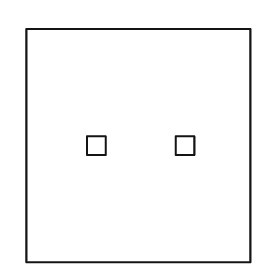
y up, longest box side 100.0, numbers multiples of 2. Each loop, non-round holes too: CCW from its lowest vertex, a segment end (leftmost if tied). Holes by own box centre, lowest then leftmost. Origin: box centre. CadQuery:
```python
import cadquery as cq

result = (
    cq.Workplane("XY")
    .moveTo(-48.0, -50.0)
    .lineTo(48.0, -50.0)
    .lineTo(48.0, 50.0)
    .lineTo(-48.0, 50.0)
    .close()
    .moveTo(-22.0, -4.0)
    .lineTo(-14.0, -4.0)
    .lineTo(-14.0, 4.0)
    .lineTo(-22.0, 4.0)
    .close()
    .moveTo(16.0, -4.0)
    .lineTo(24.0, -4.0)
    .lineTo(24.0, 4.0)
    .lineTo(16.0, 4.0)
    .close()
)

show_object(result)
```